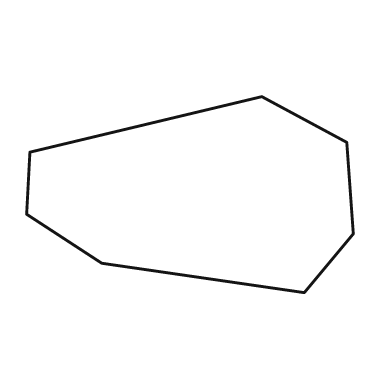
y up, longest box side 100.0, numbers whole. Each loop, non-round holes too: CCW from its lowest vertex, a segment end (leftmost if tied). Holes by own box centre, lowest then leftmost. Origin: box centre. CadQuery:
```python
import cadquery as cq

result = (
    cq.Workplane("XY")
    .moveTo(35.0, -30.0)
    .lineTo(50.0, -12.0)
    .lineTo(48.0, 16.0)
    .lineTo(22.0, 30.0)
    .lineTo(-49.0, 13.0)
    .lineTo(-50.0, -6.0)
    .lineTo(-27.0, -21.0)
    .close()
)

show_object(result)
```